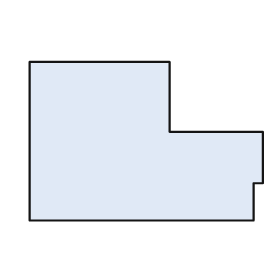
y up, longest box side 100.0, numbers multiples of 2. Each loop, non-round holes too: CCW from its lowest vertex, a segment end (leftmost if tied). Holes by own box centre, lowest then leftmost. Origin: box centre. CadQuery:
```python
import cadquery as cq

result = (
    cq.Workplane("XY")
    .moveTo(-50.0, -34.0)
    .lineTo(46.0, -34.0)
    .lineTo(46.0, -18.0)
    .lineTo(50.0, -18.0)
    .lineTo(50.0, 4.0)
    .lineTo(10.0, 4.0)
    .lineTo(10.0, 34.0)
    .lineTo(-50.0, 34.0)
    .close()
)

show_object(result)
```